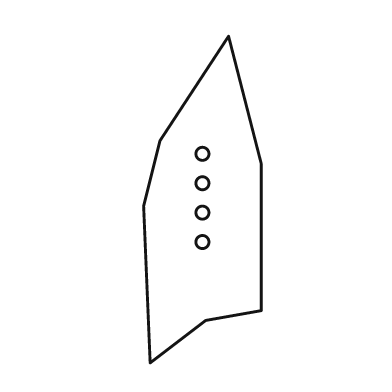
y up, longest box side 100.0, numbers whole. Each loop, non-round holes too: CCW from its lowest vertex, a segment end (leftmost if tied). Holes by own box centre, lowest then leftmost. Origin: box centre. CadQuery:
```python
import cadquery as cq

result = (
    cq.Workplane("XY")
    .moveTo(-16.0, -50.0)
    .lineTo(1.0, -37.0)
    .lineTo(18.0, -34.0)
    .lineTo(18.0, 11.0)
    .lineTo(8.0, 50.0)
    .lineTo(-13.0, 18.0)
    .lineTo(-18.0, -2.0)
    .close()
    .moveTo(0.0, -13.0)
    .circle(2.0)
    .moveTo(0.0, -4.0)
    .circle(2.0)
    .moveTo(0.0, 5.0)
    .circle(2.0)
    .moveTo(0.0, 14.0)
    .circle(2.0)
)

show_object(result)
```